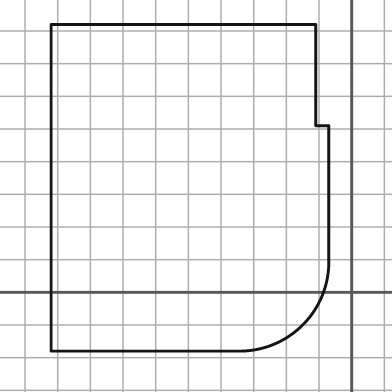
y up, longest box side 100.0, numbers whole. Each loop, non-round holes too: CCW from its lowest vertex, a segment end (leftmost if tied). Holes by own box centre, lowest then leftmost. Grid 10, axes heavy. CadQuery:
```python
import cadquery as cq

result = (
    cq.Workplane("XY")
    .moveTo(-92.0, -18.0)
    .lineTo(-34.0, -18.0)
    .threePointArc((-15.0, -10.0), (-7.0, 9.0))
    .lineTo(-7.0, 51.0)
    .lineTo(-11.0, 51.0)
    .lineTo(-11.0, 82.0)
    .lineTo(-92.0, 82.0)
    .close()
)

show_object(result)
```